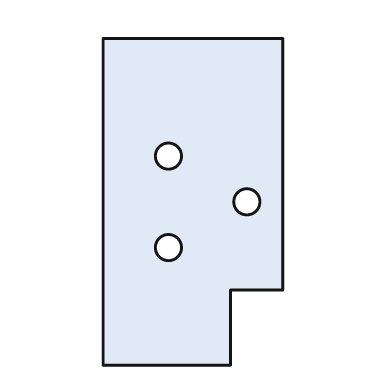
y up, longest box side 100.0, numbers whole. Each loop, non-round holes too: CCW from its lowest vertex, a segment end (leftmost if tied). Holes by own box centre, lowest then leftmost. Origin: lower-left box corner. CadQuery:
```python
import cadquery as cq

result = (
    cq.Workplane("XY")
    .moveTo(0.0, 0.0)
    .lineTo(39.0, 0.0)
    .lineTo(39.0, 23.0)
    .lineTo(55.0, 23.0)
    .lineTo(55.0, 100.0)
    .lineTo(0.0, 100.0)
    .close()
    .moveTo(20.0, 36.0)
    .circle(4.0)
    .moveTo(44.0, 50.0)
    .circle(4.0)
    .moveTo(20.0, 64.0)
    .circle(4.0)
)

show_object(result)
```